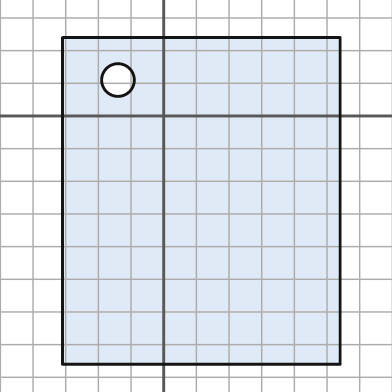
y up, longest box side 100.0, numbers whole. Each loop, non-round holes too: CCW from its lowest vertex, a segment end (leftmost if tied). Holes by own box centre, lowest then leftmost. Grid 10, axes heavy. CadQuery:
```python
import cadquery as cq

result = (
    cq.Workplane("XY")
    .moveTo(-31.0, -76.0)
    .lineTo(54.0, -76.0)
    .lineTo(54.0, 24.0)
    .lineTo(-31.0, 24.0)
    .close()
    .moveTo(-14.0, 11.0)
    .circle(5.0)
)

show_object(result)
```